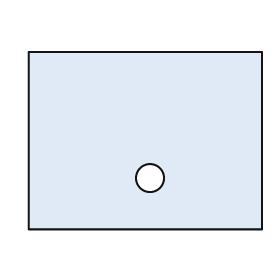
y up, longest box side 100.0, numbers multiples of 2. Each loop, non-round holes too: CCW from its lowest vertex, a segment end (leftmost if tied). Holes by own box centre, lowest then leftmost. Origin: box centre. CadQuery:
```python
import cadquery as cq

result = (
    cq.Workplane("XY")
    .moveTo(-50.0, -38.0)
    .lineTo(50.0, -38.0)
    .lineTo(50.0, 38.0)
    .lineTo(-50.0, 38.0)
    .close()
    .moveTo(2.0, -16.0)
    .circle(6.0)
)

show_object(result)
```